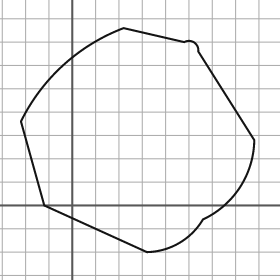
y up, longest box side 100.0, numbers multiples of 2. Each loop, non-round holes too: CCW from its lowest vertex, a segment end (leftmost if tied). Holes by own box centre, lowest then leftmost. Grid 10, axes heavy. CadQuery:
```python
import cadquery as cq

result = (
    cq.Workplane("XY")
    .moveTo(32.0, -20.0)
    .threePointArc((46.0, -16.0), (56.0, -6.0))
    .threePointArc((72.0, 8.0), (78.0, 28.0))
    .lineTo(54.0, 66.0)
    .threePointArc((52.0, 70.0), (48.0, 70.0))
    .lineTo(22.0, 76.0)
    .threePointArc((-4.0, 60.0), (-22.0, 36.0))
    .lineTo(-12.0, 0.0)
    .close()
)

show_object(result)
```